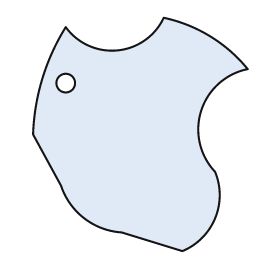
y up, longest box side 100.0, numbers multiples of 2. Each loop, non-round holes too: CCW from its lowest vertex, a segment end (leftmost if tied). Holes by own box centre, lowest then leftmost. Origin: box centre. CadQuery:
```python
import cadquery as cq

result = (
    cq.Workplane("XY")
    .moveTo(18.0, -50.0)
    .threePointArc((32.0, -36.0), (32.0, -16.0))
    .threePointArc((26.0, 10.0), (46.0, 28.0))
    .threePointArc((30.0, 42.0), (10.0, 50.0))
    .threePointArc((-10.0, 36.0), (-32.0, 46.0))
    .threePointArc((-42.0, 24.0), (-46.0, 0.0))
    .lineTo(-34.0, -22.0)
    .threePointArc((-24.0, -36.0), (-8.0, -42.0))
    .close()
    .moveTo(-32.0, 22.0)
    .circle(4.0)
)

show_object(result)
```